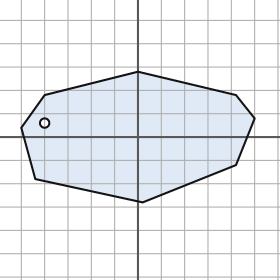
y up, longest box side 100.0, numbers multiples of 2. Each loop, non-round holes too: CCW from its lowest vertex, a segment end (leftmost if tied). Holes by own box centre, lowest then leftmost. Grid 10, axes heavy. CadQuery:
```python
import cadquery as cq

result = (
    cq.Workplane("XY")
    .moveTo(2.0, -28.0)
    .lineTo(42.0, -12.0)
    .lineTo(50.0, 8.0)
    .lineTo(42.0, 18.0)
    .lineTo(0.0, 28.0)
    .lineTo(-40.0, 18.0)
    .lineTo(-50.0, 4.0)
    .lineTo(-44.0, -18.0)
    .close()
    .moveTo(-40.0, 6.0)
    .circle(2.0)
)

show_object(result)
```